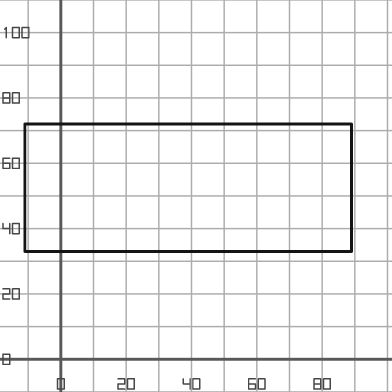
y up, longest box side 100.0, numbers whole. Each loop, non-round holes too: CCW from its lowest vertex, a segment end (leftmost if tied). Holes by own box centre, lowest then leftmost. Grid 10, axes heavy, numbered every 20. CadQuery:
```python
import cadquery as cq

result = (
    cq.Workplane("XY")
    .moveTo(-11.0, 33.0)
    .lineTo(89.0, 33.0)
    .lineTo(89.0, 72.0)
    .lineTo(-11.0, 72.0)
    .close()
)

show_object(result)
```